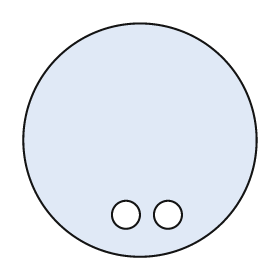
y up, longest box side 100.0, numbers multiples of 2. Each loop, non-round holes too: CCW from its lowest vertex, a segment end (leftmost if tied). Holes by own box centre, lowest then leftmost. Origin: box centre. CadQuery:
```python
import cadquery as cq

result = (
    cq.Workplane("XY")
    .moveTo(0.0, 0.0)
    .circle(50.0)
    .moveTo(-6.0, -32.0)
    .circle(6.0)
    .moveTo(12.0, -32.0)
    .circle(6.0)
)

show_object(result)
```